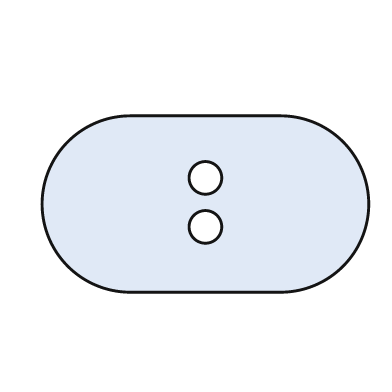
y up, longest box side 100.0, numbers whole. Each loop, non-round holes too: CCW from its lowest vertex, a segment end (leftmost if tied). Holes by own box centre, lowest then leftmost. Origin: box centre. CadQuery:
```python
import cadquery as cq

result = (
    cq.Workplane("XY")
    .moveTo(-23.0, -27.0)
    .lineTo(23.0, -27.0)
    .threePointArc((50.0, 0.0), (23.0, 27.0))
    .lineTo(-23.0, 27.0)
    .threePointArc((-50.0, 0.0), (-23.0, -27.0))
    .close()
    .moveTo(0.0, -7.0)
    .circle(5.0)
    .moveTo(0.0, 8.0)
    .circle(5.0)
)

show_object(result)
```